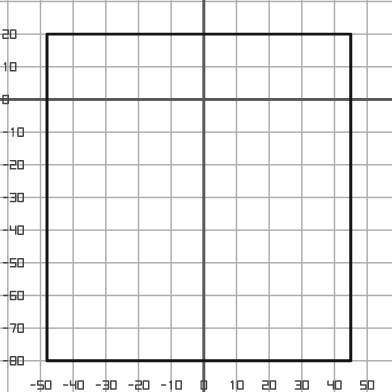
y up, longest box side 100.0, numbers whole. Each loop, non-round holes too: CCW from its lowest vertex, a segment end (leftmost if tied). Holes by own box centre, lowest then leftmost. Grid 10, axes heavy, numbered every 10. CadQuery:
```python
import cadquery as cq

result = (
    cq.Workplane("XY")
    .moveTo(-48.0, -80.0)
    .lineTo(45.0, -80.0)
    .lineTo(45.0, 20.0)
    .lineTo(-48.0, 20.0)
    .close()
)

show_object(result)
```